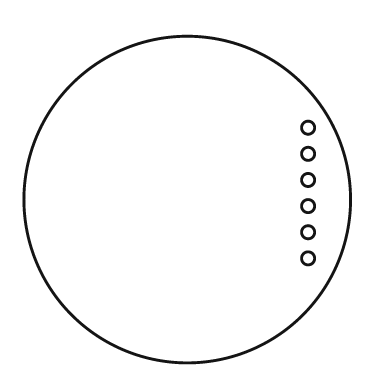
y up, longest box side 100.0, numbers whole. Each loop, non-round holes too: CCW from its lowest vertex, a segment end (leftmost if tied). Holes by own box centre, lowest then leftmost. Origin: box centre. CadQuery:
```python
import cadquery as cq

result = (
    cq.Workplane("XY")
    .moveTo(0.0, 0.0)
    .circle(50.0)
    .moveTo(37.0, -18.0)
    .circle(2.0)
    .moveTo(37.0, -10.0)
    .circle(2.0)
    .moveTo(37.0, -2.0)
    .circle(2.0)
    .moveTo(37.0, 6.0)
    .circle(2.0)
    .moveTo(37.0, 14.0)
    .circle(2.0)
    .moveTo(37.0, 22.0)
    .circle(2.0)
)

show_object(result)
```